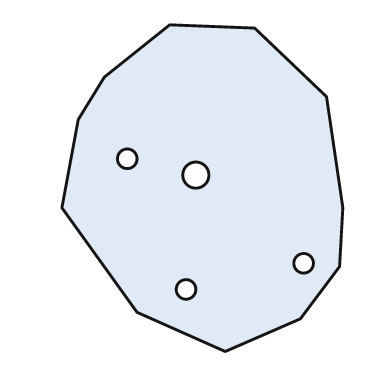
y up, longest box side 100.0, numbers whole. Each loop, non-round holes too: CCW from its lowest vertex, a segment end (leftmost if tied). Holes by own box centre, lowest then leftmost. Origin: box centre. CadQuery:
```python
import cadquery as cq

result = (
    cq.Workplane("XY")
    .moveTo(7.0, -50.0)
    .lineTo(30.0, -40.0)
    .lineTo(42.0, -24.0)
    .lineTo(43.0, -6.0)
    .lineTo(38.0, 28.0)
    .lineTo(16.0, 49.0)
    .lineTo(-10.0, 50.0)
    .lineTo(-30.0, 34.0)
    .lineTo(-38.0, 21.0)
    .lineTo(-43.0, -6.0)
    .lineTo(-20.0, -38.0)
    .close()
    .moveTo(-5.0, -31.0)
    .circle(3.0)
    .moveTo(31.0, -23.0)
    .circle(3.0)
    .moveTo(-2.0, 4.0)
    .circle(4.0)
    .moveTo(-23.0, 9.0)
    .circle(3.0)
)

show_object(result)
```